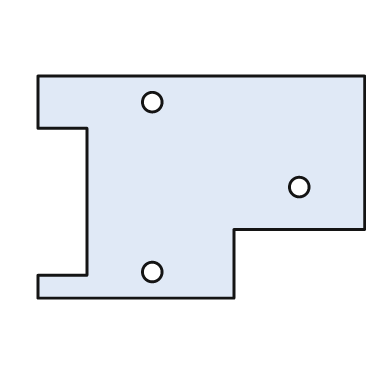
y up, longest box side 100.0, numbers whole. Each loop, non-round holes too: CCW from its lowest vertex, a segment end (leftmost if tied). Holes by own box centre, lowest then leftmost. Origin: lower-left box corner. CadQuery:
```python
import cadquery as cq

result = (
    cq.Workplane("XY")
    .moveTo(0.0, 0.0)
    .lineTo(60.0, 0.0)
    .lineTo(60.0, 21.0)
    .lineTo(100.0, 21.0)
    .lineTo(100.0, 68.0)
    .lineTo(0.0, 68.0)
    .lineTo(0.0, 52.0)
    .lineTo(15.0, 52.0)
    .lineTo(15.0, 7.0)
    .lineTo(0.0, 7.0)
    .close()
    .moveTo(35.0, 8.0)
    .circle(3.0)
    .moveTo(80.0, 34.0)
    .circle(3.0)
    .moveTo(35.0, 60.0)
    .circle(3.0)
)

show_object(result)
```